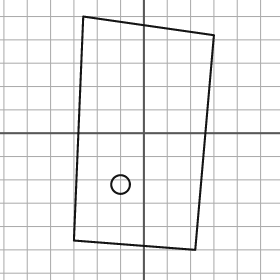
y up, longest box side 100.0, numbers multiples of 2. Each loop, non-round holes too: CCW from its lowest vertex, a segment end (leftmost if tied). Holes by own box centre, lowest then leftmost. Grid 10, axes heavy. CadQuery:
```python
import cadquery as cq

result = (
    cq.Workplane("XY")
    .moveTo(22.0, -50.0)
    .lineTo(30.0, 42.0)
    .lineTo(-26.0, 50.0)
    .lineTo(-30.0, -46.0)
    .close()
    .moveTo(-10.0, -22.0)
    .circle(4.0)
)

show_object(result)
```